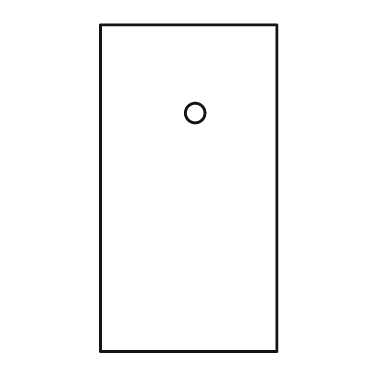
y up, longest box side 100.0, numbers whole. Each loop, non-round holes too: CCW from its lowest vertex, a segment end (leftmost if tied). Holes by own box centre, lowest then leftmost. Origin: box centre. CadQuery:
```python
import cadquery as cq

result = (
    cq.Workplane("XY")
    .moveTo(-27.0, -50.0)
    .lineTo(27.0, -50.0)
    .lineTo(27.0, 50.0)
    .lineTo(-27.0, 50.0)
    .close()
    .moveTo(2.0, 23.0)
    .circle(3.0)
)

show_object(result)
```